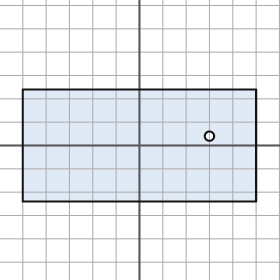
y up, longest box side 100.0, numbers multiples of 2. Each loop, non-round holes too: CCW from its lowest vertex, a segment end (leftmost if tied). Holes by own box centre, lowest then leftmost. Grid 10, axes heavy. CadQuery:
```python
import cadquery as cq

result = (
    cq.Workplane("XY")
    .moveTo(-50.0, -24.0)
    .lineTo(50.0, -24.0)
    .lineTo(50.0, 24.0)
    .lineTo(-50.0, 24.0)
    .close()
    .moveTo(30.0, 4.0)
    .circle(2.0)
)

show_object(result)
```